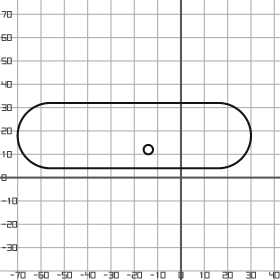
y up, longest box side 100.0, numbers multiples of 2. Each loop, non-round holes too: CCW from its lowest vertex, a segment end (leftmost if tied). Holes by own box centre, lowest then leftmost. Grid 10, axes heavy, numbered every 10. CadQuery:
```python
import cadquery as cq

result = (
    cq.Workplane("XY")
    .moveTo(-56.0, 4.0)
    .lineTo(16.0, 4.0)
    .threePointArc((30.0, 18.0), (16.0, 32.0))
    .lineTo(-56.0, 32.0)
    .threePointArc((-70.0, 18.0), (-56.0, 4.0))
    .close()
    .moveTo(-14.0, 12.0)
    .circle(2.0)
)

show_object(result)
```